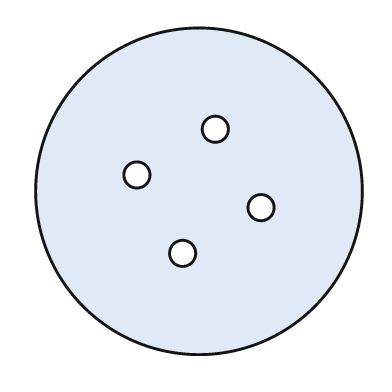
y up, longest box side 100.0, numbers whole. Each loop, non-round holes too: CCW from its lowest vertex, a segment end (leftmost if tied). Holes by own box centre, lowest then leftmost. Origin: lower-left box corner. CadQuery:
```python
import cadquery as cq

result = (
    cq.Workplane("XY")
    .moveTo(50.0, 50.0)
    .circle(50.0)
    .moveTo(45.0, 31.0)
    .circle(4.0)
    .moveTo(69.0, 45.0)
    .circle(4.0)
    .moveTo(31.0, 55.0)
    .circle(4.0)
    .moveTo(55.0, 69.0)
    .circle(4.0)
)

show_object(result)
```